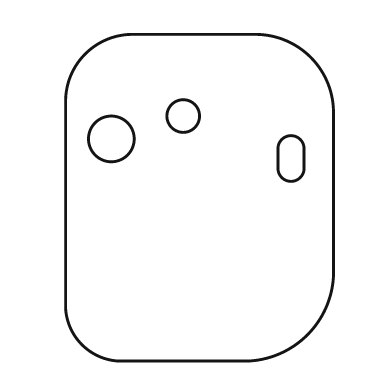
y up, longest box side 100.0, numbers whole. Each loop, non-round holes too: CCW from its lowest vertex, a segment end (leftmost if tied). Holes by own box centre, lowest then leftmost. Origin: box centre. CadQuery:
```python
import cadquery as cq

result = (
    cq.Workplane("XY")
    .moveTo(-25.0, -50.0)
    .lineTo(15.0, -50.0)
    .threePointArc((33.0, -42.0), (41.0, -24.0))
    .lineTo(41.0, 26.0)
    .threePointArc((34.0, 43.0), (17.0, 50.0))
    .lineTo(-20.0, 50.0)
    .threePointArc((-35.0, 44.0), (-41.0, 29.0))
    .lineTo(-41.0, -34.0)
    .threePointArc((-36.0, -45.0), (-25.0, -50.0))
    .close()
    .moveTo(24.0, 9.0)
    .threePointArc((28.0, 5.0), (32.0, 9.0))
    .lineTo(32.0, 15.0)
    .threePointArc((28.0, 19.0), (24.0, 15.0))
    .close()
    .moveTo(-27.0, 18.0)
    .circle(7.0)
    .moveTo(-5.0, 25.0)
    .circle(5.0)
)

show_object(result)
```